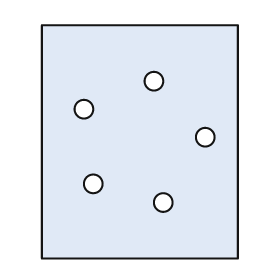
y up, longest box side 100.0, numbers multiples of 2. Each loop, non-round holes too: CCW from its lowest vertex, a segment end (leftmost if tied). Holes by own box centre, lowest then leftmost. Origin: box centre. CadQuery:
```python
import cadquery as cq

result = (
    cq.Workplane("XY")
    .moveTo(-42.0, -50.0)
    .lineTo(42.0, -50.0)
    .lineTo(42.0, 50.0)
    .lineTo(-42.0, 50.0)
    .close()
    .moveTo(10.0, -26.0)
    .circle(4.0)
    .moveTo(-20.0, -18.0)
    .circle(4.0)
    .moveTo(28.0, 2.0)
    .circle(4.0)
    .moveTo(-24.0, 14.0)
    .circle(4.0)
    .moveTo(6.0, 26.0)
    .circle(4.0)
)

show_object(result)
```